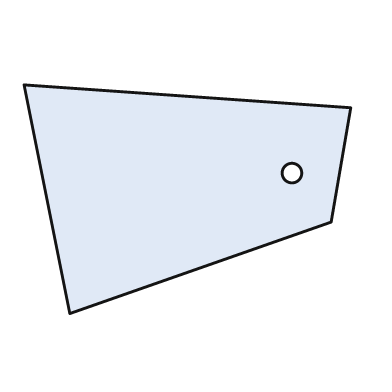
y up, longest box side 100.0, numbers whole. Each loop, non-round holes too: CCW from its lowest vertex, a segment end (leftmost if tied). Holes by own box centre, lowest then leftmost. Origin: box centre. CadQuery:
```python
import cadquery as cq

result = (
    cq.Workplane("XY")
    .moveTo(-36.0, -35.0)
    .lineTo(44.0, -7.0)
    .lineTo(50.0, 28.0)
    .lineTo(-50.0, 35.0)
    .close()
    .moveTo(32.0, 8.0)
    .circle(3.0)
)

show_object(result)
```